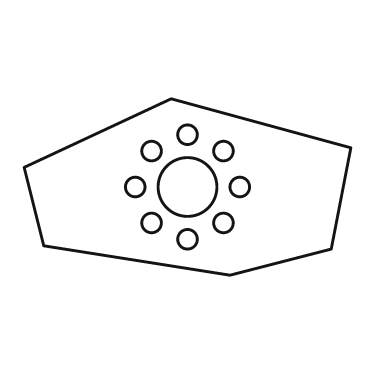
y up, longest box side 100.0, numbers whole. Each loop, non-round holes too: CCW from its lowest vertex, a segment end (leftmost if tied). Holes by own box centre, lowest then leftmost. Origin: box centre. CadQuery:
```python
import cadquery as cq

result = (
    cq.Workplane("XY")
    .moveTo(13.0, -27.0)
    .lineTo(44.0, -19.0)
    .lineTo(50.0, 12.0)
    .lineTo(-5.0, 27.0)
    .lineTo(-50.0, 6.0)
    .lineTo(-44.0, -18.0)
    .close()
    .moveTo(0.0, -16.0)
    .circle(3.0)
    .moveTo(-11.0, -11.0)
    .circle(3.0)
    .moveTo(11.0, -11.0)
    .circle(3.0)
    .moveTo(-16.0, 0.0)
    .circle(3.0)
    .moveTo(0.0, 0.0)
    .circle(9.0)
    .moveTo(16.0, 0.0)
    .circle(3.0)
    .moveTo(-11.0, 11.0)
    .circle(3.0)
    .moveTo(11.0, 11.0)
    .circle(3.0)
    .moveTo(0.0, 16.0)
    .circle(3.0)
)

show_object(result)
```